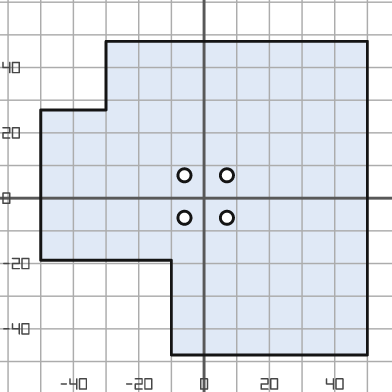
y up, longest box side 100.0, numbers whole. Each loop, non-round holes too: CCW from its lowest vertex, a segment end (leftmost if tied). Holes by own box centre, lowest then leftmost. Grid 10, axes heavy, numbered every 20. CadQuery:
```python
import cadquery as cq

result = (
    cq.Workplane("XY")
    .moveTo(-10.0, -48.0)
    .lineTo(50.0, -48.0)
    .lineTo(50.0, 48.0)
    .lineTo(-30.0, 48.0)
    .lineTo(-30.0, 27.0)
    .lineTo(-50.0, 27.0)
    .lineTo(-50.0, -19.0)
    .lineTo(-10.0, -19.0)
    .close()
    .moveTo(-6.0, -6.0)
    .circle(2.0)
    .moveTo(7.0, -6.0)
    .circle(2.0)
    .moveTo(-6.0, 7.0)
    .circle(2.0)
    .moveTo(7.0, 7.0)
    .circle(2.0)
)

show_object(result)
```